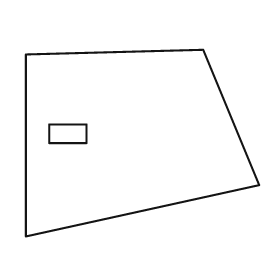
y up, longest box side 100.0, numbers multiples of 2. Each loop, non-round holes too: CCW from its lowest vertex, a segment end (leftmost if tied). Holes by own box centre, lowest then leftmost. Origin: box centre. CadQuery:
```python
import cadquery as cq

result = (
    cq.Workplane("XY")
    .moveTo(-50.0, -40.0)
    .lineTo(50.0, -18.0)
    .lineTo(26.0, 40.0)
    .lineTo(-50.0, 38.0)
    .close()
    .moveTo(-40.0, 0.0)
    .lineTo(-24.0, 0.0)
    .lineTo(-24.0, 8.0)
    .lineTo(-40.0, 8.0)
    .close()
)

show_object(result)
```